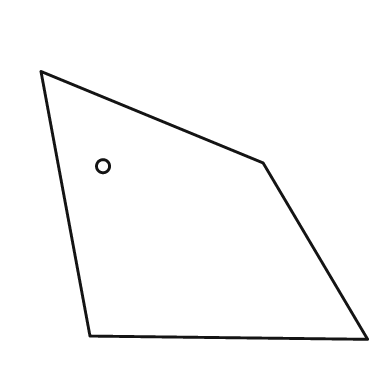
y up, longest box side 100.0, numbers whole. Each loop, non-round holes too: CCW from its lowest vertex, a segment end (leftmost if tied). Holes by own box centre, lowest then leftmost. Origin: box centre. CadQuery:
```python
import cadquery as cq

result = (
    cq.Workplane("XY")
    .moveTo(50.0, -41.0)
    .lineTo(18.0, 13.0)
    .lineTo(-50.0, 41.0)
    .lineTo(-35.0, -40.0)
    .close()
    .moveTo(-31.0, 12.0)
    .circle(2.0)
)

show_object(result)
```